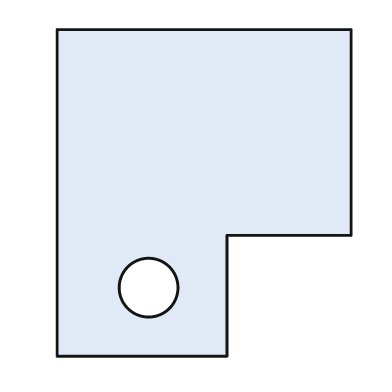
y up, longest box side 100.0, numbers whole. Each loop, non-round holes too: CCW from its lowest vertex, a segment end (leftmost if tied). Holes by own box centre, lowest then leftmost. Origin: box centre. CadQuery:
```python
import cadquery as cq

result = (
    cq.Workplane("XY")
    .moveTo(-45.0, -50.0)
    .lineTo(7.0, -50.0)
    .lineTo(7.0, -13.0)
    .lineTo(45.0, -13.0)
    .lineTo(45.0, 50.0)
    .lineTo(-45.0, 50.0)
    .close()
    .moveTo(-17.0, -29.0)
    .circle(9.0)
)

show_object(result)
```